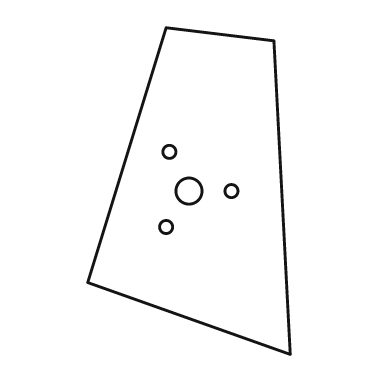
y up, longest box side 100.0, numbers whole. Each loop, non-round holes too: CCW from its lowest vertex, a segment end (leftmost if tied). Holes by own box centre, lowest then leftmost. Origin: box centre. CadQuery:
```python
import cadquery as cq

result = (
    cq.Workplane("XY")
    .moveTo(31.0, -50.0)
    .lineTo(26.0, 46.0)
    .lineTo(-7.0, 50.0)
    .lineTo(-31.0, -28.0)
    .close()
    .moveTo(-7.0, -11.0)
    .circle(2.0)
    .moveTo(0.0, 0.0)
    .circle(4.0)
    .moveTo(13.0, 0.0)
    .circle(2.0)
    .moveTo(-6.0, 12.0)
    .circle(2.0)
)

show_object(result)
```